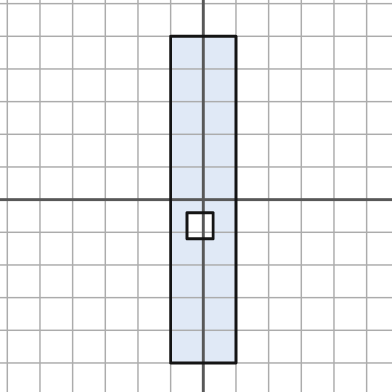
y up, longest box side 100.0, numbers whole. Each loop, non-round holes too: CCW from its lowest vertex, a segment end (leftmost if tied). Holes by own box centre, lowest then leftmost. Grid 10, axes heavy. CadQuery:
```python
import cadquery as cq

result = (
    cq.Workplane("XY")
    .moveTo(-10.0, -50.0)
    .lineTo(10.0, -50.0)
    .lineTo(10.0, 50.0)
    .lineTo(-10.0, 50.0)
    .close()
    .moveTo(-5.0, -12.0)
    .lineTo(3.0, -12.0)
    .lineTo(3.0, -4.0)
    .lineTo(-5.0, -4.0)
    .close()
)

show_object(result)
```